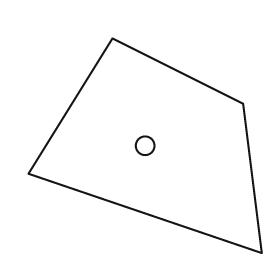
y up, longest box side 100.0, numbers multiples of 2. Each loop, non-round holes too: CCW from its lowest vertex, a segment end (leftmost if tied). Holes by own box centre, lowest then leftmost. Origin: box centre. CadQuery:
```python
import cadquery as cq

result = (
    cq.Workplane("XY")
    .moveTo(50.0, -46.0)
    .lineTo(42.0, 18.0)
    .lineTo(-14.0, 46.0)
    .lineTo(-50.0, -12.0)
    .close()
    .moveTo(0.0, 0.0)
    .circle(4.0)
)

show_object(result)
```